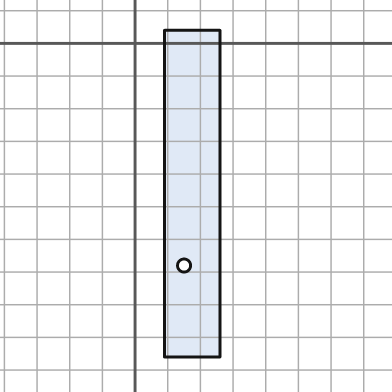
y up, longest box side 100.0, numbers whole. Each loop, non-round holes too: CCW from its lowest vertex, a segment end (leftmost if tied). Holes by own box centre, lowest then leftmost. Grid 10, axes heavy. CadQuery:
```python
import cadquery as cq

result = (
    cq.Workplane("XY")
    .moveTo(9.0, -96.0)
    .lineTo(26.0, -96.0)
    .lineTo(26.0, 4.0)
    .lineTo(9.0, 4.0)
    .close()
    .moveTo(15.0, -68.0)
    .circle(2.0)
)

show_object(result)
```